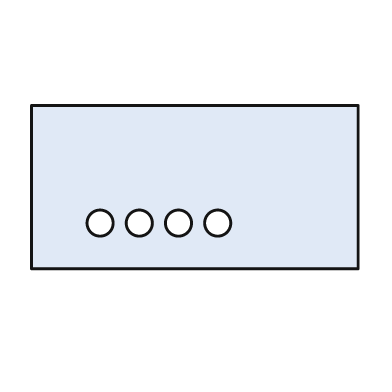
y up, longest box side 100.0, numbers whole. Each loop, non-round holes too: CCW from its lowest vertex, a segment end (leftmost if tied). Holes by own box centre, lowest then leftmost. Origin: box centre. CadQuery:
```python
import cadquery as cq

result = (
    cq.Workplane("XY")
    .moveTo(-50.0, -25.0)
    .lineTo(50.0, -25.0)
    .lineTo(50.0, 25.0)
    .lineTo(-50.0, 25.0)
    .close()
    .moveTo(-29.0, -11.0)
    .circle(4.0)
    .moveTo(-17.0, -11.0)
    .circle(4.0)
    .moveTo(-5.0, -11.0)
    .circle(4.0)
    .moveTo(7.0, -11.0)
    .circle(4.0)
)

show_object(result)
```